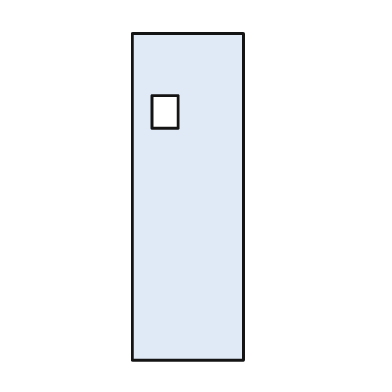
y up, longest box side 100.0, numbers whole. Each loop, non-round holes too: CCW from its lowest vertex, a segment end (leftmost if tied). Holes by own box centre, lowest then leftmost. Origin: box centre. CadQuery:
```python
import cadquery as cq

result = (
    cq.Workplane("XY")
    .moveTo(-17.0, -50.0)
    .lineTo(17.0, -50.0)
    .lineTo(17.0, 50.0)
    .lineTo(-17.0, 50.0)
    .close()
    .moveTo(-11.0, 21.0)
    .lineTo(-3.0, 21.0)
    .lineTo(-3.0, 31.0)
    .lineTo(-11.0, 31.0)
    .close()
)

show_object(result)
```